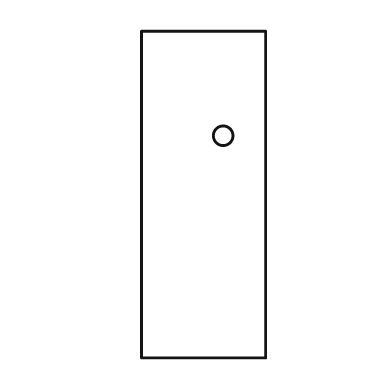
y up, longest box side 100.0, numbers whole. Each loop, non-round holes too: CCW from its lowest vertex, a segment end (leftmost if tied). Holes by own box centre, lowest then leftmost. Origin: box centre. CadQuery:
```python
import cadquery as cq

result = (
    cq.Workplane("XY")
    .moveTo(-19.0, -50.0)
    .lineTo(19.0, -50.0)
    .lineTo(19.0, 50.0)
    .lineTo(-19.0, 50.0)
    .close()
    .moveTo(6.0, 18.0)
    .circle(3.0)
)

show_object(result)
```